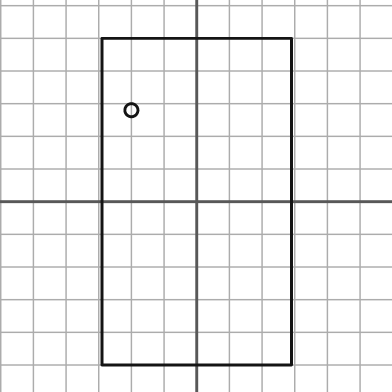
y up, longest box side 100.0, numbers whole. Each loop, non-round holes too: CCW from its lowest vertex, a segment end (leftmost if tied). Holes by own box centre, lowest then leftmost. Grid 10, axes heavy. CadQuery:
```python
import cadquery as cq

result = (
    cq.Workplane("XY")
    .moveTo(-29.0, -50.0)
    .lineTo(29.0, -50.0)
    .lineTo(29.0, 50.0)
    .lineTo(-29.0, 50.0)
    .close()
    .moveTo(-20.0, 28.0)
    .circle(2.0)
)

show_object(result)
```